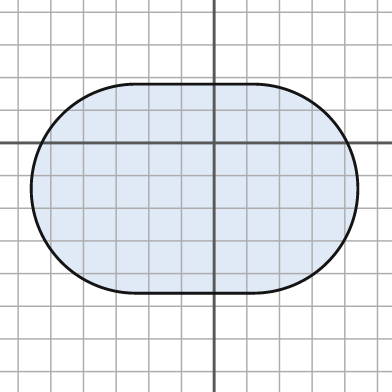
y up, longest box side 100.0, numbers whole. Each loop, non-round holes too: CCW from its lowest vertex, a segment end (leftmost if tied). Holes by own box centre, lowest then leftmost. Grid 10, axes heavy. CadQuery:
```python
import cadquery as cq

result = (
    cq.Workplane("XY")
    .moveTo(-24.0, -46.0)
    .lineTo(12.0, -46.0)
    .threePointArc((44.0, -14.0), (12.0, 18.0))
    .lineTo(-24.0, 18.0)
    .threePointArc((-56.0, -14.0), (-24.0, -46.0))
    .close()
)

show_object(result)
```